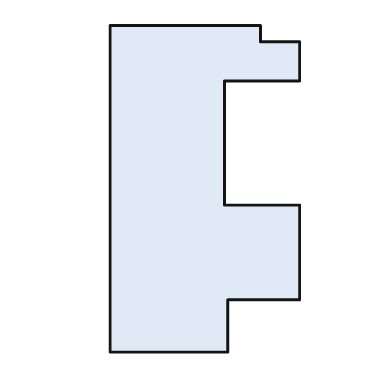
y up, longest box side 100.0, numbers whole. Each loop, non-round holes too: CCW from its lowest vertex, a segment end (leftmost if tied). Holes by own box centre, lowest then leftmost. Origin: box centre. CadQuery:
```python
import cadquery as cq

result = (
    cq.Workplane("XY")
    .moveTo(-29.0, -50.0)
    .lineTo(7.0, -50.0)
    .lineTo(7.0, -34.0)
    .lineTo(29.0, -34.0)
    .lineTo(29.0, -5.0)
    .lineTo(6.0, -5.0)
    .lineTo(6.0, 33.0)
    .lineTo(29.0, 33.0)
    .lineTo(29.0, 45.0)
    .lineTo(17.0, 45.0)
    .lineTo(17.0, 50.0)
    .lineTo(-29.0, 50.0)
    .close()
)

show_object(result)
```